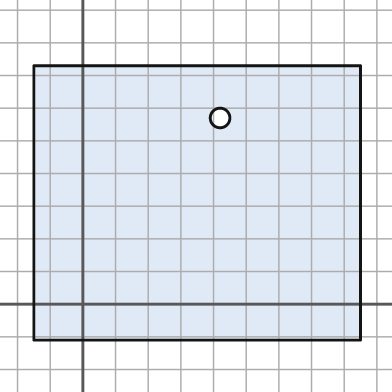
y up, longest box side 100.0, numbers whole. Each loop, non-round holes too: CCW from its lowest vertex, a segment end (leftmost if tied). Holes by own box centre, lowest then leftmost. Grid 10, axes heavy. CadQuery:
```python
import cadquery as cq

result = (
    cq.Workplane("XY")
    .moveTo(-15.0, -11.0)
    .lineTo(85.0, -11.0)
    .lineTo(85.0, 73.0)
    .lineTo(-15.0, 73.0)
    .close()
    .moveTo(42.0, 57.0)
    .circle(3.0)
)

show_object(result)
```